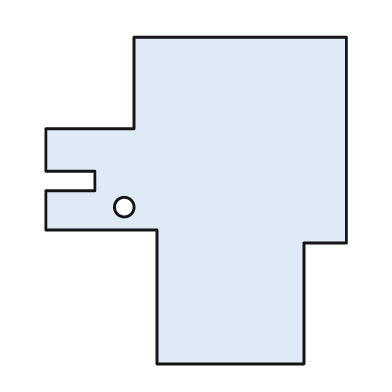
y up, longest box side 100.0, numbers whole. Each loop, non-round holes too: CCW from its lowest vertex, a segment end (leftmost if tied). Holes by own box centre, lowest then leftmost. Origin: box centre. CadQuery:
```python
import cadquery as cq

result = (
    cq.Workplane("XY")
    .moveTo(-12.0, -50.0)
    .lineTo(33.0, -50.0)
    .lineTo(33.0, -13.0)
    .lineTo(46.0, -13.0)
    .lineTo(46.0, 50.0)
    .lineTo(-19.0, 50.0)
    .lineTo(-19.0, 22.0)
    .lineTo(-46.0, 22.0)
    .lineTo(-46.0, 9.0)
    .lineTo(-31.0, 9.0)
    .lineTo(-31.0, 3.0)
    .lineTo(-46.0, 3.0)
    .lineTo(-46.0, -9.0)
    .lineTo(-12.0, -9.0)
    .close()
    .moveTo(-22.0, -2.0)
    .circle(3.0)
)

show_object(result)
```